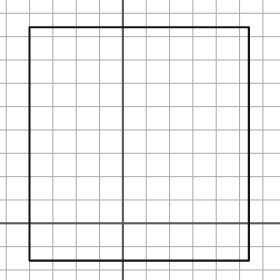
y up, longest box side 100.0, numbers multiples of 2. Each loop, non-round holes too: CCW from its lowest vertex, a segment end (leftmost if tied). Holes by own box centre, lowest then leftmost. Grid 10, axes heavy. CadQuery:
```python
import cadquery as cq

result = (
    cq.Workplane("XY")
    .moveTo(-40.0, -16.0)
    .lineTo(54.0, -16.0)
    .lineTo(54.0, 84.0)
    .lineTo(-40.0, 84.0)
    .close()
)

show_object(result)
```